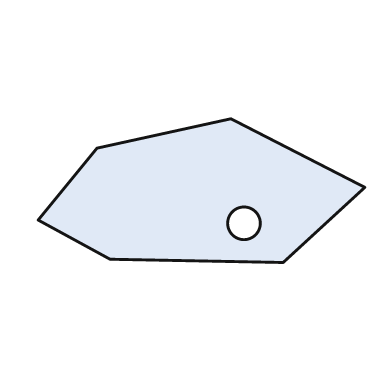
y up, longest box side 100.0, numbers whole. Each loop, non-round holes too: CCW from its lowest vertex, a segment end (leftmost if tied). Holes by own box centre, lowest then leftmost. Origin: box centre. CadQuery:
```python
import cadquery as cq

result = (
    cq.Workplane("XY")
    .moveTo(25.0, -22.0)
    .lineTo(50.0, 1.0)
    .lineTo(9.0, 22.0)
    .lineTo(-32.0, 13.0)
    .lineTo(-50.0, -9.0)
    .lineTo(-28.0, -21.0)
    .close()
    .moveTo(13.0, -10.0)
    .circle(5.0)
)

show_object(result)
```